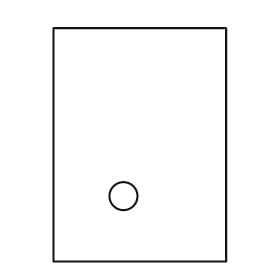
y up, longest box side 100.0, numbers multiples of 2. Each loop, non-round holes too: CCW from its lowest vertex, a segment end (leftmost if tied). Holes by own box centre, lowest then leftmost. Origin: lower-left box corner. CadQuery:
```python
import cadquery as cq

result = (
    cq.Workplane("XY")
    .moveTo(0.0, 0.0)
    .lineTo(74.0, 0.0)
    .lineTo(74.0, 100.0)
    .lineTo(0.0, 100.0)
    .close()
    .moveTo(30.0, 28.0)
    .circle(6.0)
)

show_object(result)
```